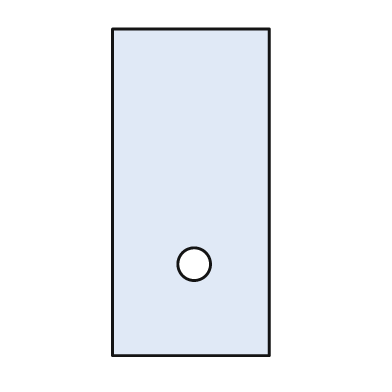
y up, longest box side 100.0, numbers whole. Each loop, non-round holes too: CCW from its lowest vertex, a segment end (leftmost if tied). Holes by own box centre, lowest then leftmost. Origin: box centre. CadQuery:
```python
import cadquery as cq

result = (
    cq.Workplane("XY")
    .moveTo(-24.0, -50.0)
    .lineTo(24.0, -50.0)
    .lineTo(24.0, 50.0)
    .lineTo(-24.0, 50.0)
    .close()
    .moveTo(1.0, -22.0)
    .circle(5.0)
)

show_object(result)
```